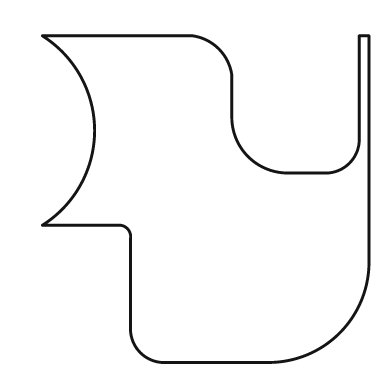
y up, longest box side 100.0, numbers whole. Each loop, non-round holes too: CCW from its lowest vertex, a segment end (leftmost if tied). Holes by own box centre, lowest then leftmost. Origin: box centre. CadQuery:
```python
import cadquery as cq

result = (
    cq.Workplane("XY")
    .moveTo(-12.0, -50.0)
    .lineTo(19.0, -50.0)
    .threePointArc((41.0, -41.0), (50.0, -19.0))
    .lineTo(50.0, 50.0)
    .lineTo(47.0, 50.0)
    .lineTo(47.0, 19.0)
    .threePointArc((44.0, 11.0), (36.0, 8.0))
    .lineTo(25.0, 8.0)
    .threePointArc((13.0, 13.0), (8.0, 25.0))
    .lineTo(8.0, 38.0)
    .threePointArc((4.0, 46.0), (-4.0, 50.0))
    .lineTo(-50.0, 50.0)
    .threePointArc((-34.0, 21.0), (-50.0, -8.0))
    .lineTo(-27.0, -8.0)
    .threePointArc((-24.0, -9.0), (-23.0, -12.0))
    .lineTo(-23.0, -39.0)
    .threePointArc((-20.0, -47.0), (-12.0, -50.0))
    .close()
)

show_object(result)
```